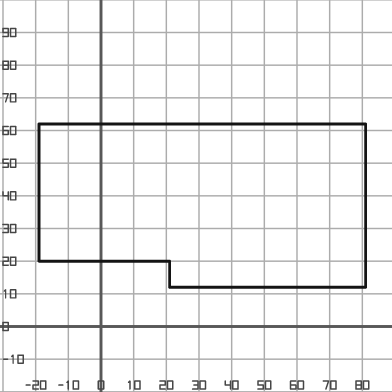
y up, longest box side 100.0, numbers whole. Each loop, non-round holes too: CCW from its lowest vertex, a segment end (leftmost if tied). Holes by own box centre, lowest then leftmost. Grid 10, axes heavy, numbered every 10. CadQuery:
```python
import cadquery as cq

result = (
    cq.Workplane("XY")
    .moveTo(21.0, 12.0)
    .lineTo(81.0, 12.0)
    .lineTo(81.0, 62.0)
    .lineTo(-19.0, 62.0)
    .lineTo(-19.0, 20.0)
    .lineTo(21.0, 20.0)
    .close()
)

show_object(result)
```